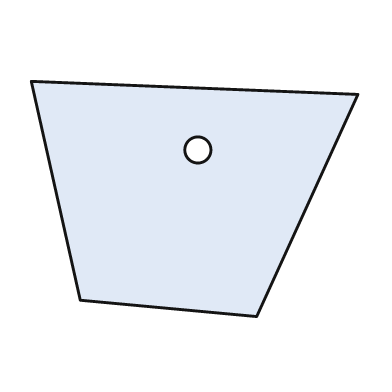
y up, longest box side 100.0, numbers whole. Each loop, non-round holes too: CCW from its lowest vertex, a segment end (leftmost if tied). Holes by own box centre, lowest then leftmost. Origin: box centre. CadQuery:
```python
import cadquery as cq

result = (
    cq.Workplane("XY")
    .moveTo(19.0, -36.0)
    .lineTo(50.0, 32.0)
    .lineTo(-50.0, 36.0)
    .lineTo(-35.0, -31.0)
    .close()
    .moveTo(1.0, 15.0)
    .circle(4.0)
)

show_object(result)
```